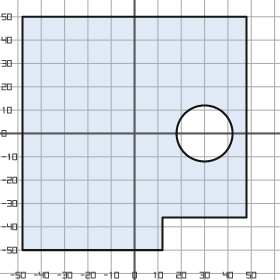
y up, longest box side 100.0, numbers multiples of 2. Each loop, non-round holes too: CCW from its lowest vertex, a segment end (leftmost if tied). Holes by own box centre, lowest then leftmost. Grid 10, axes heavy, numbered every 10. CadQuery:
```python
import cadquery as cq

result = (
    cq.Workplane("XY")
    .moveTo(-48.0, -50.0)
    .lineTo(12.0, -50.0)
    .lineTo(12.0, -36.0)
    .lineTo(48.0, -36.0)
    .lineTo(48.0, 50.0)
    .lineTo(-48.0, 50.0)
    .close()
    .moveTo(30.0, 0.0)
    .circle(12.0)
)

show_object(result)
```